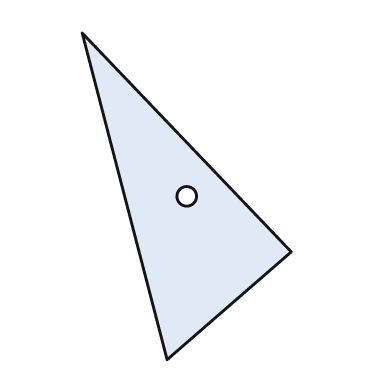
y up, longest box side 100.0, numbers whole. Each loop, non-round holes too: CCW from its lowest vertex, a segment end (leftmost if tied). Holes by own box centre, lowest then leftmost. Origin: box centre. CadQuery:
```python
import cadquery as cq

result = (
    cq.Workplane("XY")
    .moveTo(-6.0, -50.0)
    .lineTo(32.0, -17.0)
    .lineTo(-32.0, 50.0)
    .close()
    .moveTo(0.0, 0.0)
    .circle(3.0)
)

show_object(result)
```